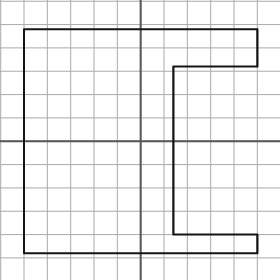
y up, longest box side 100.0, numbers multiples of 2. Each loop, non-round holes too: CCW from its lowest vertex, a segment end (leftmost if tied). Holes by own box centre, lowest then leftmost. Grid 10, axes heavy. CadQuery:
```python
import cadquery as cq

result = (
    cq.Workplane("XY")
    .moveTo(-50.0, -48.0)
    .lineTo(50.0, -48.0)
    .lineTo(50.0, -40.0)
    .lineTo(14.0, -40.0)
    .lineTo(14.0, 32.0)
    .lineTo(50.0, 32.0)
    .lineTo(50.0, 48.0)
    .lineTo(-50.0, 48.0)
    .close()
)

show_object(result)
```